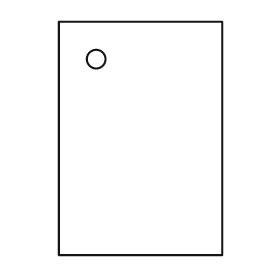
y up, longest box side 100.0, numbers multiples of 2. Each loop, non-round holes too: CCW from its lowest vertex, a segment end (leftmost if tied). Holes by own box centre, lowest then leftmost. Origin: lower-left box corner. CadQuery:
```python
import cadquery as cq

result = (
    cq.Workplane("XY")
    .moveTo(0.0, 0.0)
    .lineTo(70.0, 0.0)
    .lineTo(70.0, 100.0)
    .lineTo(0.0, 100.0)
    .close()
    .moveTo(16.0, 84.0)
    .circle(4.0)
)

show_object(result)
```